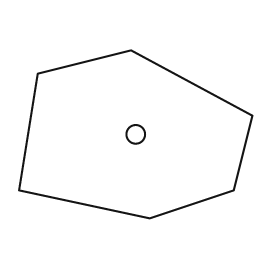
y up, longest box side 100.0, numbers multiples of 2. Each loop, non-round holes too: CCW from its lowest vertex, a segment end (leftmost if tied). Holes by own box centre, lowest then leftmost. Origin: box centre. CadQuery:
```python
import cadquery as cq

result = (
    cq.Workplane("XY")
    .moveTo(6.0, -36.0)
    .lineTo(42.0, -24.0)
    .lineTo(50.0, 8.0)
    .lineTo(-2.0, 36.0)
    .lineTo(-42.0, 26.0)
    .lineTo(-50.0, -24.0)
    .close()
    .moveTo(0.0, 0.0)
    .circle(4.0)
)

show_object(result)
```